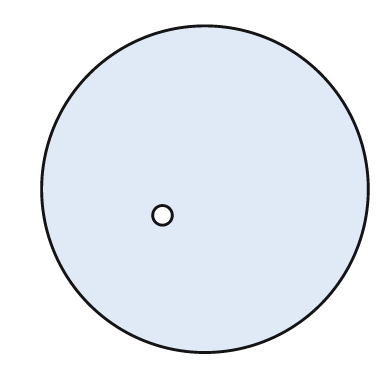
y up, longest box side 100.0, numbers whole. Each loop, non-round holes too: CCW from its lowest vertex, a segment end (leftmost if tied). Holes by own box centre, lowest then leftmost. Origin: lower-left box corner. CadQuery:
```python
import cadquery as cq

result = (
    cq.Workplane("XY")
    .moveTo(50.0, 50.0)
    .circle(50.0)
    .moveTo(37.0, 42.0)
    .circle(3.0)
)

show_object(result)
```